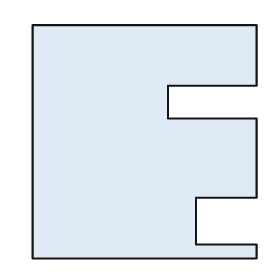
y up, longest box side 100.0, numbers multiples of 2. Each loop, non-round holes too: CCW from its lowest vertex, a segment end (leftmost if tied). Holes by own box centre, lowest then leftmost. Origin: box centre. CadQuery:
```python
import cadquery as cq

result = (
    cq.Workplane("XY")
    .moveTo(-48.0, -50.0)
    .lineTo(48.0, -50.0)
    .lineTo(48.0, -44.0)
    .lineTo(22.0, -44.0)
    .lineTo(22.0, -24.0)
    .lineTo(48.0, -24.0)
    .lineTo(48.0, 10.0)
    .lineTo(10.0, 10.0)
    .lineTo(10.0, 24.0)
    .lineTo(48.0, 24.0)
    .lineTo(48.0, 50.0)
    .lineTo(-48.0, 50.0)
    .close()
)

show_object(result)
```